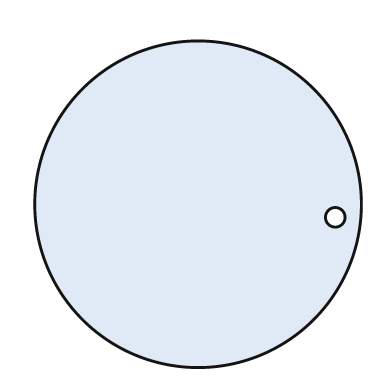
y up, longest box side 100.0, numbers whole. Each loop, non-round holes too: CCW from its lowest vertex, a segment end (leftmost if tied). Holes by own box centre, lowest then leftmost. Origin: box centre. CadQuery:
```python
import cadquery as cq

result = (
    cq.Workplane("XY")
    .moveTo(0.0, 0.0)
    .circle(50.0)
    .moveTo(42.0, -4.0)
    .circle(3.0)
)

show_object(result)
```